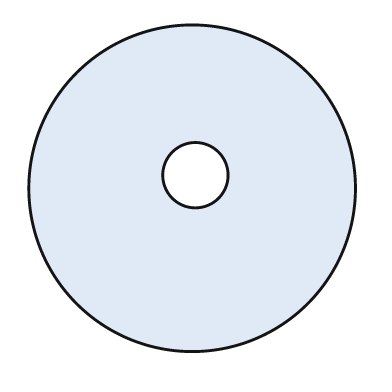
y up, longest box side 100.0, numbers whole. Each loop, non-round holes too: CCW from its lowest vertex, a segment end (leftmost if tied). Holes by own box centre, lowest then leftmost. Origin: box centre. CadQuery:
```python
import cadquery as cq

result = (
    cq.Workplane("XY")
    .moveTo(0.0, 0.0)
    .circle(50.0)
    .moveTo(1.0, 4.0)
    .circle(10.0)
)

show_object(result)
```